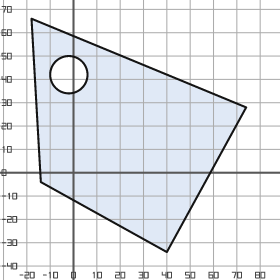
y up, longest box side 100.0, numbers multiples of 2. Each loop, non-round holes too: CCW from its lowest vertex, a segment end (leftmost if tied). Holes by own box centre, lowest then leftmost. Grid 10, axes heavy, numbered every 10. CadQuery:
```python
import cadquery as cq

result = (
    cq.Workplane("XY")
    .moveTo(40.0, -34.0)
    .lineTo(74.0, 28.0)
    .lineTo(-18.0, 66.0)
    .lineTo(-14.0, -4.0)
    .close()
    .moveTo(-2.0, 42.0)
    .circle(8.0)
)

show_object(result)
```